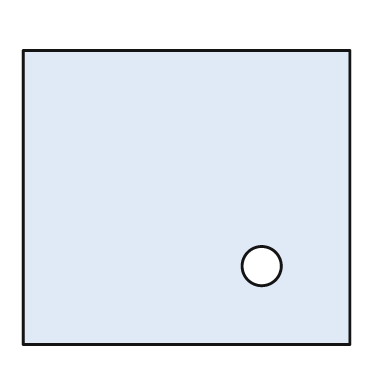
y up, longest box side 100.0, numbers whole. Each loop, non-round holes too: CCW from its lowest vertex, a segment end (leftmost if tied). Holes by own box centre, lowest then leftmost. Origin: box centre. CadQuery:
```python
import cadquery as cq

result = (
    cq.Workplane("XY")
    .moveTo(-50.0, -45.0)
    .lineTo(50.0, -45.0)
    .lineTo(50.0, 45.0)
    .lineTo(-50.0, 45.0)
    .close()
    .moveTo(23.0, -21.0)
    .circle(6.0)
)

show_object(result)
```